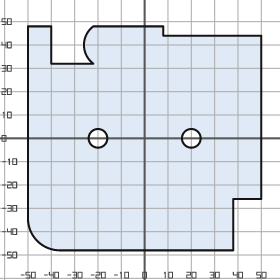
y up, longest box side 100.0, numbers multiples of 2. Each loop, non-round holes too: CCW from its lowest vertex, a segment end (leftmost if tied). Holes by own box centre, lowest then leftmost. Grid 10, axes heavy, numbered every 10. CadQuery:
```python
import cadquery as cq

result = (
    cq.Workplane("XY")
    .moveTo(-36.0, -48.0)
    .lineTo(38.0, -48.0)
    .lineTo(38.0, -26.0)
    .lineTo(50.0, -26.0)
    .lineTo(50.0, 44.0)
    .lineTo(8.0, 44.0)
    .lineTo(8.0, 48.0)
    .lineTo(-22.0, 48.0)
    .threePointArc((-26.0, 40.0), (-22.0, 32.0))
    .lineTo(-40.0, 32.0)
    .lineTo(-40.0, 48.0)
    .lineTo(-50.0, 48.0)
    .lineTo(-50.0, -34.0)
    .threePointArc((-46.0, -44.0), (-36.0, -48.0))
    .close()
    .moveTo(-20.0, 0.0)
    .circle(4.0)
    .moveTo(20.0, 0.0)
    .circle(4.0)
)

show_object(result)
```